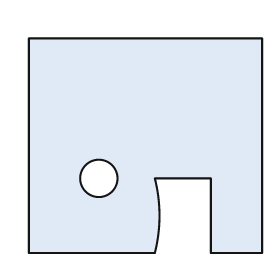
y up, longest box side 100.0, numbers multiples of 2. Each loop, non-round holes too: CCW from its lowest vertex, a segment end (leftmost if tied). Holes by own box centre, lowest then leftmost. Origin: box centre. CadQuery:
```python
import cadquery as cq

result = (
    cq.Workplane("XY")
    .moveTo(-50.0, -46.0)
    .lineTo(4.0, -46.0)
    .threePointArc((6.0, -30.0), (4.0, -14.0))
    .lineTo(28.0, -14.0)
    .lineTo(28.0, -46.0)
    .lineTo(50.0, -46.0)
    .lineTo(50.0, 46.0)
    .lineTo(-50.0, 46.0)
    .close()
    .moveTo(-20.0, -14.0)
    .circle(8.0)
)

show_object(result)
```